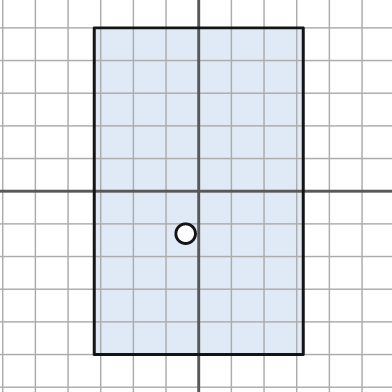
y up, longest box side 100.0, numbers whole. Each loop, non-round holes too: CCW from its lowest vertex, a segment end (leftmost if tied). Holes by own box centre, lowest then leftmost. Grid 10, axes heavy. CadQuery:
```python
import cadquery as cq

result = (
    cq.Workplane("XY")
    .moveTo(-32.0, -50.0)
    .lineTo(32.0, -50.0)
    .lineTo(32.0, 50.0)
    .lineTo(-32.0, 50.0)
    .close()
    .moveTo(-4.0, -13.0)
    .circle(3.0)
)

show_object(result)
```